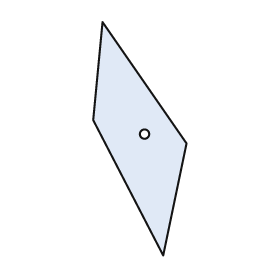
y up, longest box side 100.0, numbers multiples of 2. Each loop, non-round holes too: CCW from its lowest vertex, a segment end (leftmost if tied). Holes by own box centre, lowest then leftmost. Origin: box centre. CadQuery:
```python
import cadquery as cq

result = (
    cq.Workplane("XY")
    .moveTo(10.0, -50.0)
    .lineTo(20.0, -2.0)
    .lineTo(-16.0, 50.0)
    .lineTo(-20.0, 8.0)
    .close()
    .moveTo(2.0, 2.0)
    .circle(2.0)
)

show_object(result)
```